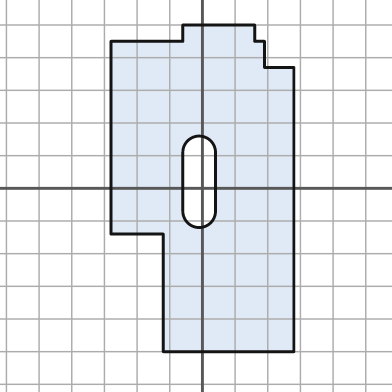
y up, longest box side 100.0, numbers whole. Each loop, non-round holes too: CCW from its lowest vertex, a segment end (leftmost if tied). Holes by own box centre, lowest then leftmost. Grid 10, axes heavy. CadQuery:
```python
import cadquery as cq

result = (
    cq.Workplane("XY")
    .moveTo(-12.0, -50.0)
    .lineTo(28.0, -50.0)
    .lineTo(28.0, 37.0)
    .lineTo(19.0, 37.0)
    .lineTo(19.0, 45.0)
    .lineTo(16.0, 45.0)
    .lineTo(16.0, 50.0)
    .lineTo(-6.0, 50.0)
    .lineTo(-6.0, 45.0)
    .lineTo(-28.0, 45.0)
    .lineTo(-28.0, -14.0)
    .lineTo(-12.0, -14.0)
    .close()
    .moveTo(-6.0, -7.0)
    .threePointArc((-1.0, -12.0), (4.0, -7.0))
    .lineTo(4.0, 11.0)
    .threePointArc((-1.0, 16.0), (-6.0, 11.0))
    .close()
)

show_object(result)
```